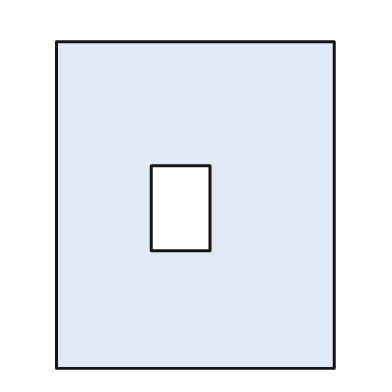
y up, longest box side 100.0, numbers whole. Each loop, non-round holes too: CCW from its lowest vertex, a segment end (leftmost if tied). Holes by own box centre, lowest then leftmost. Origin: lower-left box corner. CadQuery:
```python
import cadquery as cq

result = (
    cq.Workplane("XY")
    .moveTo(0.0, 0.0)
    .lineTo(85.0, 0.0)
    .lineTo(85.0, 100.0)
    .lineTo(0.0, 100.0)
    .close()
    .moveTo(29.0, 36.0)
    .lineTo(47.0, 36.0)
    .lineTo(47.0, 62.0)
    .lineTo(29.0, 62.0)
    .close()
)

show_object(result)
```